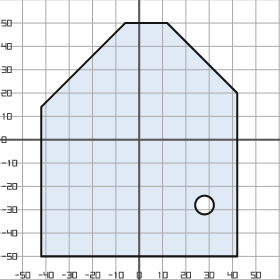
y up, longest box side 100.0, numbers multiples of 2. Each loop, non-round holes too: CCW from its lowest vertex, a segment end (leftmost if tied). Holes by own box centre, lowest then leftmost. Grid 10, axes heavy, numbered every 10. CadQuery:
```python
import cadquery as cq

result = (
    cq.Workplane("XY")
    .moveTo(-42.0, -50.0)
    .lineTo(42.0, -50.0)
    .lineTo(42.0, 20.0)
    .lineTo(12.0, 50.0)
    .lineTo(-6.0, 50.0)
    .lineTo(-42.0, 14.0)
    .close()
    .moveTo(28.0, -28.0)
    .circle(4.0)
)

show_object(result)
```